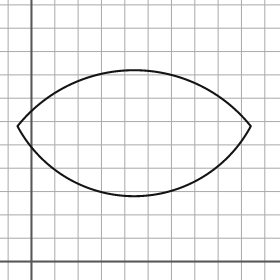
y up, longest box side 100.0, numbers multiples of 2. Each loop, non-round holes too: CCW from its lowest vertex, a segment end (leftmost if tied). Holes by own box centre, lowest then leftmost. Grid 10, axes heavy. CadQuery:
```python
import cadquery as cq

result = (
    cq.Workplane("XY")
    .moveTo(-6.0, 58.0)
    .threePointArc((44.0, 28.0), (94.0, 58.0))
    .threePointArc((44.0, 82.0), (-6.0, 58.0))
    .close()
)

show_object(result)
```